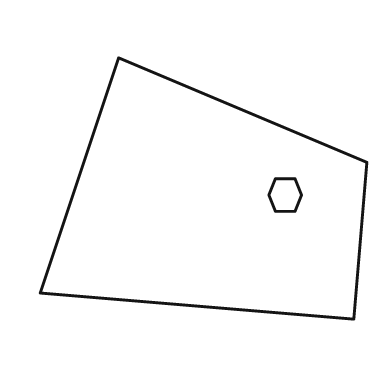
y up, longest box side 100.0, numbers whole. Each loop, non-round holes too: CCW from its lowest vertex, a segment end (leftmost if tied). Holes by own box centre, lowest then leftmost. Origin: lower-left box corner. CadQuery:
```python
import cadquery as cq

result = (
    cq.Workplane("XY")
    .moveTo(96.0, 0.0)
    .lineTo(100.0, 48.0)
    .lineTo(24.0, 80.0)
    .lineTo(0.0, 8.0)
    .close()
    .moveTo(72.0, 33.0)
    .lineTo(78.0, 33.0)
    .lineTo(80.0, 38.0)
    .lineTo(78.0, 43.0)
    .lineTo(72.0, 43.0)
    .lineTo(70.0, 38.0)
    .close()
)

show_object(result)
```